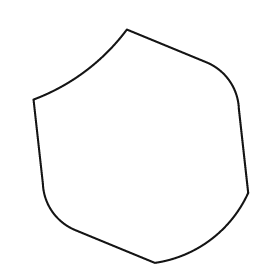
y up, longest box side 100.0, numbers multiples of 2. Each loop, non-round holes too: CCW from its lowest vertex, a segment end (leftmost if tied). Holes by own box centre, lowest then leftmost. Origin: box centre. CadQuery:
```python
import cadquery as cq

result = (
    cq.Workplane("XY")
    .moveTo(6.0, -50.0)
    .threePointArc((30.0, -40.0), (46.0, -20.0))
    .lineTo(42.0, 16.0)
    .threePointArc((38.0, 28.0), (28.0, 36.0))
    .lineTo(-6.0, 50.0)
    .threePointArc((-24.0, 32.0), (-46.0, 20.0))
    .lineTo(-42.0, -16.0)
    .threePointArc((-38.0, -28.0), (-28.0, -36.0))
    .close()
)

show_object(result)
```